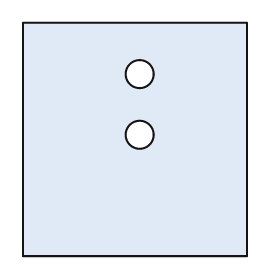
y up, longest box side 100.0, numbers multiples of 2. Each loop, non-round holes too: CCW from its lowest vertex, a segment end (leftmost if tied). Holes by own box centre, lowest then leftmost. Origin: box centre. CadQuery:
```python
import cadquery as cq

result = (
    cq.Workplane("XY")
    .moveTo(-48.0, -50.0)
    .lineTo(48.0, -50.0)
    .lineTo(48.0, 50.0)
    .lineTo(-48.0, 50.0)
    .close()
    .moveTo(2.0, 2.0)
    .circle(6.0)
    .moveTo(2.0, 28.0)
    .circle(6.0)
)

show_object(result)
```